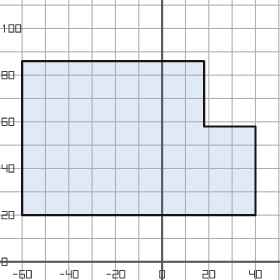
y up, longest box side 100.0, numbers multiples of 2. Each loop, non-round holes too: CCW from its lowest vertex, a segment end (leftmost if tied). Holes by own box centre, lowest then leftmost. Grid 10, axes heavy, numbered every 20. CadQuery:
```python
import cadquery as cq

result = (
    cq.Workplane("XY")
    .moveTo(-60.0, 20.0)
    .lineTo(40.0, 20.0)
    .lineTo(40.0, 58.0)
    .lineTo(18.0, 58.0)
    .lineTo(18.0, 86.0)
    .lineTo(-60.0, 86.0)
    .close()
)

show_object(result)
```